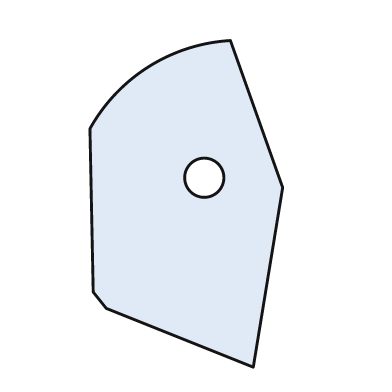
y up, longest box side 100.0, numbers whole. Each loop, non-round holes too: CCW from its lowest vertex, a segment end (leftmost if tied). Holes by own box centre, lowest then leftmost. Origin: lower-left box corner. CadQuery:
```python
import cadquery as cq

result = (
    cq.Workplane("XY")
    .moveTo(50.0, 0.0)
    .lineTo(59.0, 55.0)
    .lineTo(43.0, 100.0)
    .threePointArc((18.0, 92.0), (0.0, 73.0))
    .lineTo(1.0, 23.0)
    .lineTo(5.0, 18.0)
    .close()
    .moveTo(35.0, 58.0)
    .circle(6.0)
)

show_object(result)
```